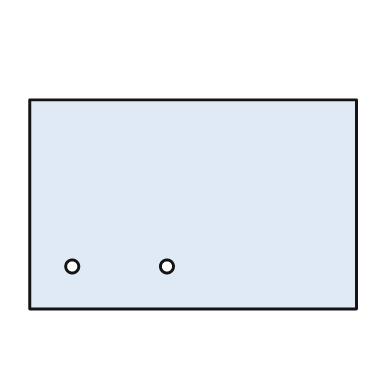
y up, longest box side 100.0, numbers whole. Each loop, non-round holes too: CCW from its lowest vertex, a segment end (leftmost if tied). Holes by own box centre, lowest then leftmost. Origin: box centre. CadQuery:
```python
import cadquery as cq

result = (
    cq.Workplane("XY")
    .moveTo(-50.0, -32.0)
    .lineTo(50.0, -32.0)
    .lineTo(50.0, 32.0)
    .lineTo(-50.0, 32.0)
    .close()
    .moveTo(-37.0, -19.0)
    .circle(2.0)
    .moveTo(-8.0, -19.0)
    .circle(2.0)
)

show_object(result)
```